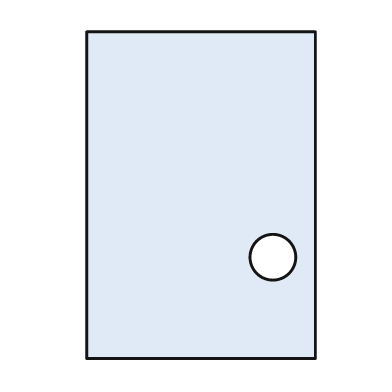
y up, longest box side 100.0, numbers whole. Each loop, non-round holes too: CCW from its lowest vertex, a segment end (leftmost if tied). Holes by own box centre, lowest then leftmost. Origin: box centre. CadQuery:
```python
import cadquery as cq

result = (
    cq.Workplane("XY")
    .moveTo(-35.0, -50.0)
    .lineTo(35.0, -50.0)
    .lineTo(35.0, 50.0)
    .lineTo(-35.0, 50.0)
    .close()
    .moveTo(22.0, -19.0)
    .circle(7.0)
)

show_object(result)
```